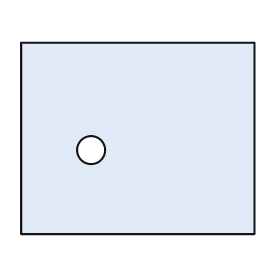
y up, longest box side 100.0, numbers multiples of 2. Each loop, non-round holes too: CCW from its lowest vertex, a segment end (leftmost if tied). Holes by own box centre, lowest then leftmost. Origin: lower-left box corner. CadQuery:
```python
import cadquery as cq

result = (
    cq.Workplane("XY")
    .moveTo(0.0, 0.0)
    .lineTo(100.0, 0.0)
    .lineTo(100.0, 82.0)
    .lineTo(0.0, 82.0)
    .close()
    .moveTo(30.0, 36.0)
    .circle(6.0)
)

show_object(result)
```